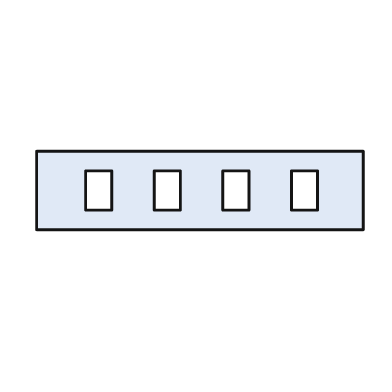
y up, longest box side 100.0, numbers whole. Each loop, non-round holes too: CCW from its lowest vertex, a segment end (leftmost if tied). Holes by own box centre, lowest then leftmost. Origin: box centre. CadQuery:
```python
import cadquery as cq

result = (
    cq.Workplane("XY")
    .moveTo(-50.0, -12.0)
    .lineTo(50.0, -12.0)
    .lineTo(50.0, 12.0)
    .lineTo(-50.0, 12.0)
    .close()
    .moveTo(-35.0, -6.0)
    .lineTo(-27.0, -6.0)
    .lineTo(-27.0, 6.0)
    .lineTo(-35.0, 6.0)
    .close()
    .moveTo(-14.0, -6.0)
    .lineTo(-6.0, -6.0)
    .lineTo(-6.0, 6.0)
    .lineTo(-14.0, 6.0)
    .close()
    .moveTo(7.0, -6.0)
    .lineTo(15.0, -6.0)
    .lineTo(15.0, 6.0)
    .lineTo(7.0, 6.0)
    .close()
    .moveTo(28.0, -6.0)
    .lineTo(36.0, -6.0)
    .lineTo(36.0, 6.0)
    .lineTo(28.0, 6.0)
    .close()
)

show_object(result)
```